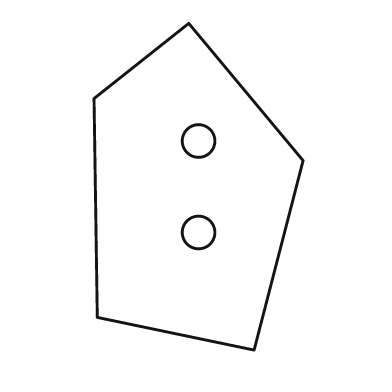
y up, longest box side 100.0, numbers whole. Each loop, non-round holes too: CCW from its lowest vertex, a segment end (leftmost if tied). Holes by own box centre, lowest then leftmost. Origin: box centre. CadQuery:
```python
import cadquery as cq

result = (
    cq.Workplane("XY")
    .moveTo(17.0, -50.0)
    .lineTo(32.0, 8.0)
    .lineTo(-3.0, 50.0)
    .lineTo(-32.0, 27.0)
    .lineTo(-31.0, -40.0)
    .close()
    .moveTo(0.0, -14.0)
    .circle(5.0)
    .moveTo(0.0, 14.0)
    .circle(5.0)
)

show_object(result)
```